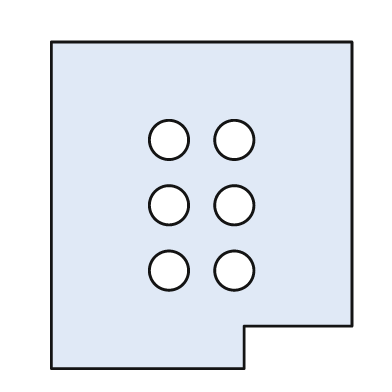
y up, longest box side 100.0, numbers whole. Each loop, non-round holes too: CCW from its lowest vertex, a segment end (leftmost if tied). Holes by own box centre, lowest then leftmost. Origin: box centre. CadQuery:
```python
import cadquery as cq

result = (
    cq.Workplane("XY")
    .moveTo(-46.0, -50.0)
    .lineTo(13.0, -50.0)
    .lineTo(13.0, -37.0)
    .lineTo(46.0, -37.0)
    .lineTo(46.0, 50.0)
    .lineTo(-46.0, 50.0)
    .close()
    .moveTo(-10.0, -20.0)
    .circle(6.0)
    .moveTo(10.0, -20.0)
    .circle(6.0)
    .moveTo(-10.0, 0.0)
    .circle(6.0)
    .moveTo(10.0, 0.0)
    .circle(6.0)
    .moveTo(-10.0, 20.0)
    .circle(6.0)
    .moveTo(10.0, 20.0)
    .circle(6.0)
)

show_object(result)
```